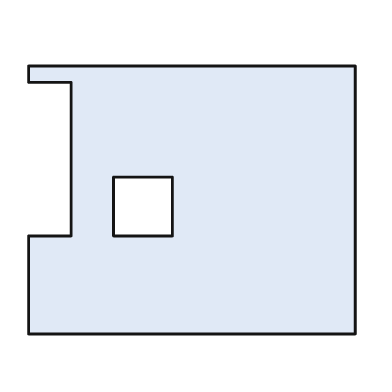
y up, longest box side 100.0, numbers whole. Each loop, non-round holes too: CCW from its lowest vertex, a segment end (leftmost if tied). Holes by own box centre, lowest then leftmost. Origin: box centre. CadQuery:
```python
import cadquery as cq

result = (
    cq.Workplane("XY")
    .moveTo(-50.0, -41.0)
    .lineTo(50.0, -41.0)
    .lineTo(50.0, 41.0)
    .lineTo(-50.0, 41.0)
    .lineTo(-50.0, 36.0)
    .lineTo(-37.0, 36.0)
    .lineTo(-37.0, -11.0)
    .lineTo(-50.0, -11.0)
    .close()
    .moveTo(-24.0, -11.0)
    .lineTo(-6.0, -11.0)
    .lineTo(-6.0, 7.0)
    .lineTo(-24.0, 7.0)
    .close()
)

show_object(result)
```